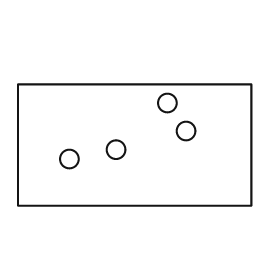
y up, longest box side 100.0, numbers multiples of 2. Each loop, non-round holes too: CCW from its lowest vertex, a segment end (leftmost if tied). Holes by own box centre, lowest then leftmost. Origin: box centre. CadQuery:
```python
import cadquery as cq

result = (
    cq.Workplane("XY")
    .moveTo(-50.0, -26.0)
    .lineTo(50.0, -26.0)
    .lineTo(50.0, 26.0)
    .lineTo(-50.0, 26.0)
    .close()
    .moveTo(-28.0, -6.0)
    .circle(4.0)
    .moveTo(-8.0, -2.0)
    .circle(4.0)
    .moveTo(22.0, 6.0)
    .circle(4.0)
    .moveTo(14.0, 18.0)
    .circle(4.0)
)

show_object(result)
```